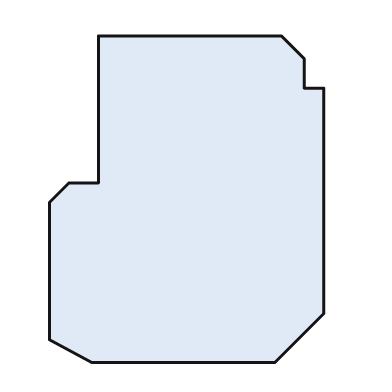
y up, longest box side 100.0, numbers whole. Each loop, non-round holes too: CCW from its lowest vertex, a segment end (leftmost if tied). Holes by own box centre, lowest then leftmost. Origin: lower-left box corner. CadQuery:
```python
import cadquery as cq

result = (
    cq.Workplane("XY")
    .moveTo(13.0, 0.0)
    .lineTo(69.0, 0.0)
    .lineTo(84.0, 15.0)
    .lineTo(84.0, 84.0)
    .lineTo(78.0, 84.0)
    .lineTo(78.0, 93.0)
    .lineTo(71.0, 100.0)
    .lineTo(15.0, 100.0)
    .lineTo(15.0, 55.0)
    .lineTo(6.0, 55.0)
    .lineTo(0.0, 49.0)
    .lineTo(0.0, 7.0)
    .close()
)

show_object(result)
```